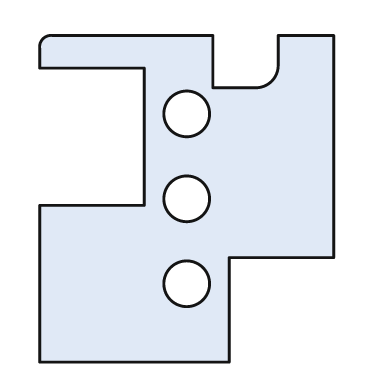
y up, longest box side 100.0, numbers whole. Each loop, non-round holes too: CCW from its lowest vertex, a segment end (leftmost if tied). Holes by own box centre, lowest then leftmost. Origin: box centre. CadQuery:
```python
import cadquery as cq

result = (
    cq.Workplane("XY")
    .moveTo(-45.0, -50.0)
    .lineTo(13.0, -50.0)
    .lineTo(13.0, -18.0)
    .lineTo(45.0, -18.0)
    .lineTo(45.0, 50.0)
    .lineTo(28.0, 50.0)
    .lineTo(28.0, 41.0)
    .threePointArc((26.0, 36.0), (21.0, 34.0))
    .lineTo(8.0, 34.0)
    .lineTo(8.0, 50.0)
    .lineTo(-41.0, 50.0)
    .threePointArc((-44.0, 49.0), (-45.0, 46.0))
    .lineTo(-45.0, 40.0)
    .lineTo(-13.0, 40.0)
    .lineTo(-13.0, -2.0)
    .lineTo(-45.0, -2.0)
    .close()
    .moveTo(0.0, -26.0)
    .circle(7.0)
    .moveTo(0.0, 0.0)
    .circle(7.0)
    .moveTo(0.0, 26.0)
    .circle(7.0)
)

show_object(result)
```